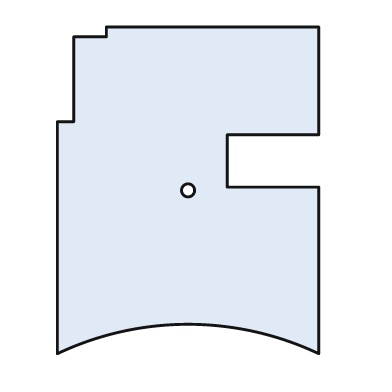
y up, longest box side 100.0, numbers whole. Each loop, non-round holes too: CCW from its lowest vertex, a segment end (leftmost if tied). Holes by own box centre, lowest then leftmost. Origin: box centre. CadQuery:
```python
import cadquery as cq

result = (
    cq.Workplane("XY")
    .moveTo(-40.0, -50.0)
    .threePointArc((0.0, -41.0), (40.0, -50.0))
    .lineTo(40.0, 1.0)
    .lineTo(12.0, 1.0)
    .lineTo(12.0, 17.0)
    .lineTo(40.0, 17.0)
    .lineTo(40.0, 50.0)
    .lineTo(-25.0, 50.0)
    .lineTo(-25.0, 47.0)
    .lineTo(-35.0, 47.0)
    .lineTo(-35.0, 21.0)
    .lineTo(-40.0, 21.0)
    .close()
    .moveTo(0.0, 0.0)
    .circle(2.0)
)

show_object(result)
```